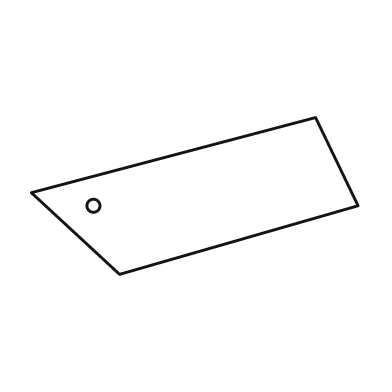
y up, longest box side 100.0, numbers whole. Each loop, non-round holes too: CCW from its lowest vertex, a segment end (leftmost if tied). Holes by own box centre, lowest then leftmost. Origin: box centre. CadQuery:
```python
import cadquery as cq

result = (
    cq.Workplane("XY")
    .moveTo(-23.0, -24.0)
    .lineTo(50.0, -3.0)
    .lineTo(37.0, 24.0)
    .lineTo(-50.0, 1.0)
    .close()
    .moveTo(-31.0, -3.0)
    .circle(2.0)
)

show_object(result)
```